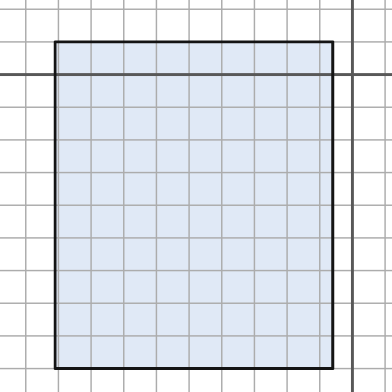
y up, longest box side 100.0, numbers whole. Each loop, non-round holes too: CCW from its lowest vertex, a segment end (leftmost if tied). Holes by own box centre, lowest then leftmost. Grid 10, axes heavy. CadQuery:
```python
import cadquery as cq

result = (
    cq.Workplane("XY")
    .moveTo(-91.0, -90.0)
    .lineTo(-6.0, -90.0)
    .lineTo(-6.0, 10.0)
    .lineTo(-91.0, 10.0)
    .close()
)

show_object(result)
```